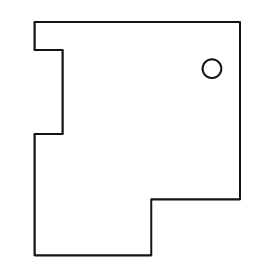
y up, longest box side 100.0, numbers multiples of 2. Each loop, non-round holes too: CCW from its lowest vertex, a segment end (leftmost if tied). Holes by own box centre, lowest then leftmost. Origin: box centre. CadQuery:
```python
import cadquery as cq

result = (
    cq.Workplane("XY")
    .moveTo(-44.0, -50.0)
    .lineTo(6.0, -50.0)
    .lineTo(6.0, -26.0)
    .lineTo(44.0, -26.0)
    .lineTo(44.0, 50.0)
    .lineTo(-44.0, 50.0)
    .lineTo(-44.0, 38.0)
    .lineTo(-32.0, 38.0)
    .lineTo(-32.0, 2.0)
    .lineTo(-44.0, 2.0)
    .close()
    .moveTo(32.0, 30.0)
    .circle(4.0)
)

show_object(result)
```